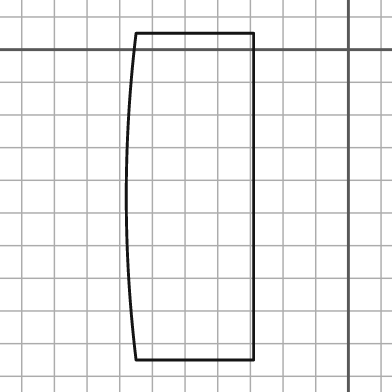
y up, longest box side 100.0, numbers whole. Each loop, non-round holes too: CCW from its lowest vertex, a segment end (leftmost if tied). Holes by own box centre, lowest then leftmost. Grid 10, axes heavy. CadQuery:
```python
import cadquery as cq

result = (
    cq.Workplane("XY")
    .moveTo(-65.0, -95.0)
    .lineTo(-29.0, -95.0)
    .lineTo(-29.0, 5.0)
    .lineTo(-65.0, 5.0)
    .threePointArc((-68.0, -45.0), (-65.0, -95.0))
    .close()
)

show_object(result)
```